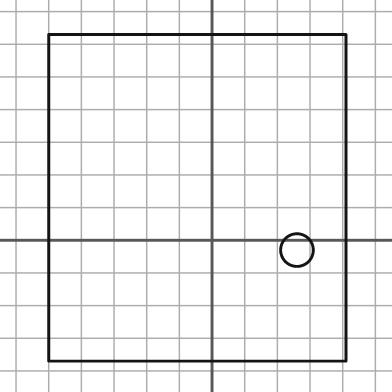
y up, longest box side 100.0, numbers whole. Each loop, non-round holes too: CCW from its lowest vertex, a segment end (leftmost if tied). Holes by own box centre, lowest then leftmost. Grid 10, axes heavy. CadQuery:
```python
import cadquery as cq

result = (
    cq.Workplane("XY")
    .moveTo(-50.0, -37.0)
    .lineTo(41.0, -37.0)
    .lineTo(41.0, 63.0)
    .lineTo(-50.0, 63.0)
    .close()
    .moveTo(26.0, -3.0)
    .circle(5.0)
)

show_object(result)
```